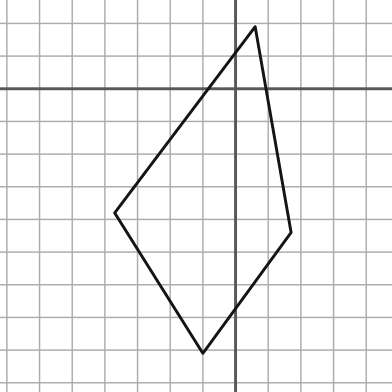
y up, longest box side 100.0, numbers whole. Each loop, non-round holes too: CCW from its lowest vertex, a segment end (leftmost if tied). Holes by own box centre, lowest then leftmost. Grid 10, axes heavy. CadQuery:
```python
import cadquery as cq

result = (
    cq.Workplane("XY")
    .moveTo(-10.0, -81.0)
    .lineTo(17.0, -44.0)
    .lineTo(6.0, 19.0)
    .lineTo(-37.0, -38.0)
    .close()
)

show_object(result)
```